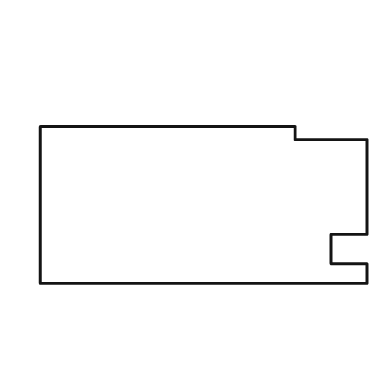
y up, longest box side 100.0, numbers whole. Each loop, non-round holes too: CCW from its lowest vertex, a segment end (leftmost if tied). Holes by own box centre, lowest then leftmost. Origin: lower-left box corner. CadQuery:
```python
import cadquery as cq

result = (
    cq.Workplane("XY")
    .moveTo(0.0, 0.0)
    .lineTo(100.0, 0.0)
    .lineTo(100.0, 6.0)
    .lineTo(89.0, 6.0)
    .lineTo(89.0, 15.0)
    .lineTo(100.0, 15.0)
    .lineTo(100.0, 44.0)
    .lineTo(78.0, 44.0)
    .lineTo(78.0, 48.0)
    .lineTo(0.0, 48.0)
    .close()
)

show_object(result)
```